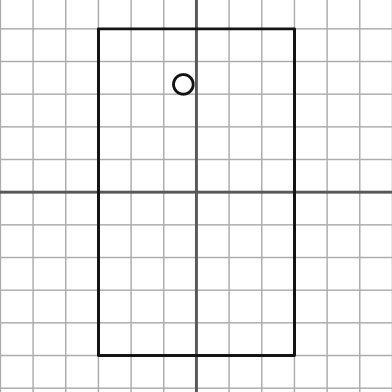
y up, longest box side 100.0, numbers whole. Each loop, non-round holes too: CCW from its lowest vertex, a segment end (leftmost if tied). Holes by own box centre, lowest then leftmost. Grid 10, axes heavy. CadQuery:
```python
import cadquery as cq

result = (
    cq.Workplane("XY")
    .moveTo(-30.0, -50.0)
    .lineTo(30.0, -50.0)
    .lineTo(30.0, 50.0)
    .lineTo(-30.0, 50.0)
    .close()
    .moveTo(-4.0, 33.0)
    .circle(3.0)
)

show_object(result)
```